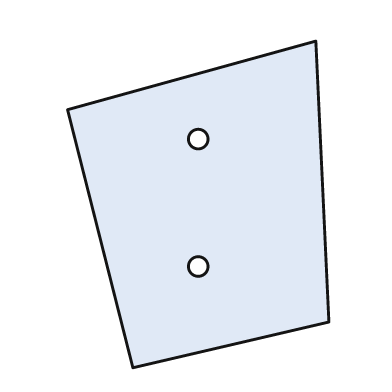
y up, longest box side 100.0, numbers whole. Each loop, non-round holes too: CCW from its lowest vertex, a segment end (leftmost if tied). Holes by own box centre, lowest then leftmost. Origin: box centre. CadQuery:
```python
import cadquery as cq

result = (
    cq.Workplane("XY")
    .moveTo(-20.0, -50.0)
    .lineTo(40.0, -36.0)
    .lineTo(36.0, 50.0)
    .lineTo(-40.0, 29.0)
    .close()
    .moveTo(0.0, -19.0)
    .circle(3.0)
    .moveTo(0.0, 20.0)
    .circle(3.0)
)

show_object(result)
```